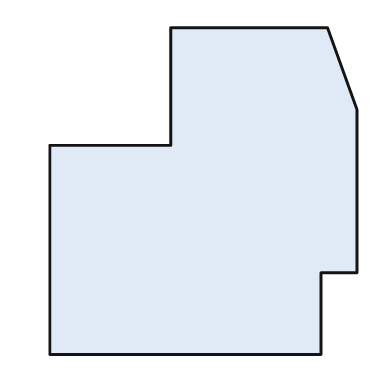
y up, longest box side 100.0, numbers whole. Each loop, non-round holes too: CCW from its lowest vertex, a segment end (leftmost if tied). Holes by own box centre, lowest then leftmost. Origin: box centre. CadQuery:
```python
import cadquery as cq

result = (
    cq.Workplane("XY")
    .moveTo(-47.0, -50.0)
    .lineTo(36.0, -50.0)
    .lineTo(36.0, -25.0)
    .lineTo(47.0, -25.0)
    .lineTo(47.0, 25.0)
    .lineTo(38.0, 50.0)
    .lineTo(-10.0, 50.0)
    .lineTo(-10.0, 14.0)
    .lineTo(-47.0, 14.0)
    .close()
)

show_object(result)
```